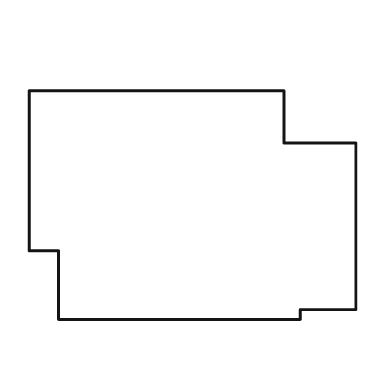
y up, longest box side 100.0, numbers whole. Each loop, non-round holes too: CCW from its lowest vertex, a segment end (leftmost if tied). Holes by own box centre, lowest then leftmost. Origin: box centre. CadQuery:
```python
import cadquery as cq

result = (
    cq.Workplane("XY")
    .moveTo(-41.0, -35.0)
    .lineTo(33.0, -35.0)
    .lineTo(33.0, -32.0)
    .lineTo(50.0, -32.0)
    .lineTo(50.0, 19.0)
    .lineTo(28.0, 19.0)
    .lineTo(28.0, 35.0)
    .lineTo(-50.0, 35.0)
    .lineTo(-50.0, -14.0)
    .lineTo(-41.0, -14.0)
    .close()
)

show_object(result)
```